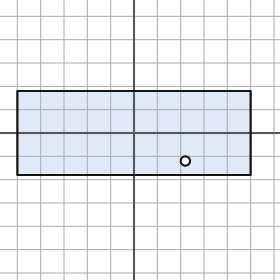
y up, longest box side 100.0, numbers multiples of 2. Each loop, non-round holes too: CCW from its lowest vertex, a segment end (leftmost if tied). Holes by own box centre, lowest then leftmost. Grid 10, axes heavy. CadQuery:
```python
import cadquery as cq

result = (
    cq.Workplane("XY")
    .moveTo(-50.0, -18.0)
    .lineTo(50.0, -18.0)
    .lineTo(50.0, 18.0)
    .lineTo(-50.0, 18.0)
    .close()
    .moveTo(22.0, -12.0)
    .circle(2.0)
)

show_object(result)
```